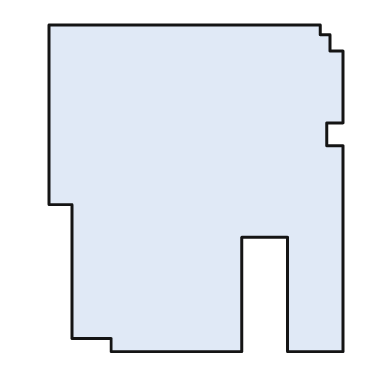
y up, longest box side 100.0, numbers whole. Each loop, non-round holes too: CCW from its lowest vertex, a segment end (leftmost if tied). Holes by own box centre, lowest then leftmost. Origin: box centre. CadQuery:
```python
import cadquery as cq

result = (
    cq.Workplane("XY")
    .moveTo(-26.0, -50.0)
    .lineTo(14.0, -50.0)
    .lineTo(14.0, -15.0)
    .lineTo(28.0, -15.0)
    .lineTo(28.0, -50.0)
    .lineTo(45.0, -50.0)
    .lineTo(45.0, 13.0)
    .lineTo(40.0, 13.0)
    .lineTo(40.0, 20.0)
    .lineTo(45.0, 20.0)
    .lineTo(45.0, 42.0)
    .lineTo(41.0, 42.0)
    .lineTo(41.0, 47.0)
    .lineTo(38.0, 47.0)
    .lineTo(38.0, 50.0)
    .lineTo(-45.0, 50.0)
    .lineTo(-45.0, -5.0)
    .lineTo(-38.0, -5.0)
    .lineTo(-38.0, -46.0)
    .lineTo(-26.0, -46.0)
    .close()
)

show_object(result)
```